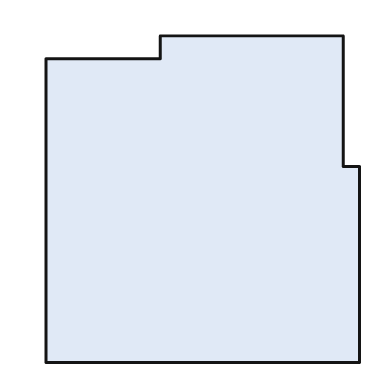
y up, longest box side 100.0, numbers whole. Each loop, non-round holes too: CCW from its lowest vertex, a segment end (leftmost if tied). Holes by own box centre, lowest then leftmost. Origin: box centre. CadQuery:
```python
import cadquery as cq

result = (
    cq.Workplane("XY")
    .moveTo(-48.0, -50.0)
    .lineTo(48.0, -50.0)
    .lineTo(48.0, 10.0)
    .lineTo(43.0, 10.0)
    .lineTo(43.0, 50.0)
    .lineTo(-13.0, 50.0)
    .lineTo(-13.0, 43.0)
    .lineTo(-48.0, 43.0)
    .close()
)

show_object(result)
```